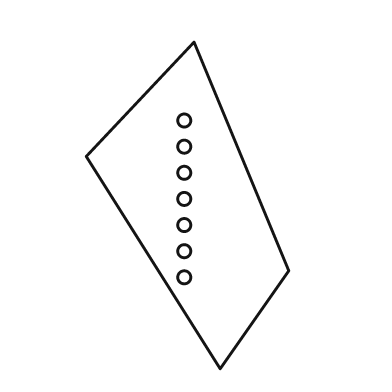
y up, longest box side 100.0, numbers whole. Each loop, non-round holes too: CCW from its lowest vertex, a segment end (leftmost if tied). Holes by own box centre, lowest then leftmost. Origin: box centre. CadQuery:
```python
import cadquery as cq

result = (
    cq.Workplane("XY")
    .moveTo(10.0, -50.0)
    .lineTo(31.0, -20.0)
    .lineTo(2.0, 50.0)
    .lineTo(-31.0, 15.0)
    .close()
    .moveTo(-1.0, -22.0)
    .circle(2.0)
    .moveTo(-1.0, -14.0)
    .circle(2.0)
    .moveTo(-1.0, -6.0)
    .circle(2.0)
    .moveTo(-1.0, 2.0)
    .circle(2.0)
    .moveTo(-1.0, 10.0)
    .circle(2.0)
    .moveTo(-1.0, 18.0)
    .circle(2.0)
    .moveTo(-1.0, 26.0)
    .circle(2.0)
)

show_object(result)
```